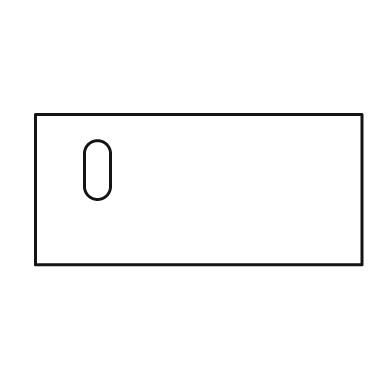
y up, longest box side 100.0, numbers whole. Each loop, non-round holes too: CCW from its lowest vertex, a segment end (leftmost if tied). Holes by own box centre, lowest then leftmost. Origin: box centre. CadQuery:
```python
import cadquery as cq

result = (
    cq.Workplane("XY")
    .moveTo(-50.0, -23.0)
    .lineTo(50.0, -23.0)
    .lineTo(50.0, 23.0)
    .lineTo(-50.0, 23.0)
    .close()
    .moveTo(-35.0, 1.0)
    .threePointArc((-31.0, -3.0), (-27.0, 1.0))
    .lineTo(-27.0, 11.0)
    .threePointArc((-31.0, 15.0), (-35.0, 11.0))
    .close()
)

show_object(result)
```